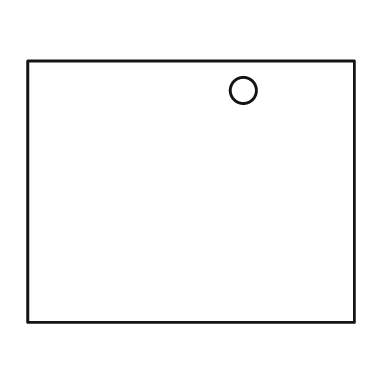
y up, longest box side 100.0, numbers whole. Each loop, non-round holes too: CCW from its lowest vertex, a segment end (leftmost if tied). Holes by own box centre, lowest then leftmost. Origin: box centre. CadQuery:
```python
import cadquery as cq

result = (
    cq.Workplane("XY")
    .moveTo(-50.0, -40.0)
    .lineTo(50.0, -40.0)
    .lineTo(50.0, 40.0)
    .lineTo(-50.0, 40.0)
    .close()
    .moveTo(16.0, 31.0)
    .circle(4.0)
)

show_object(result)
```